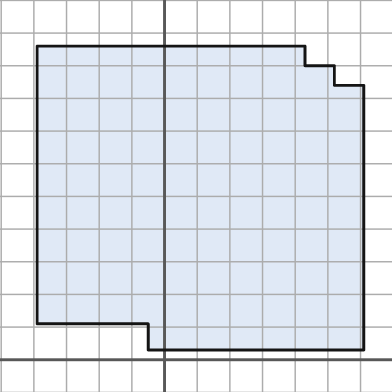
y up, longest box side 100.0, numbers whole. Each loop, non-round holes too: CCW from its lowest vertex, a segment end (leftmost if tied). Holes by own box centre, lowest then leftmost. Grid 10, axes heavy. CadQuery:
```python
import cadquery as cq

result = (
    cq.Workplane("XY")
    .moveTo(-5.0, 3.0)
    .lineTo(61.0, 3.0)
    .lineTo(61.0, 84.0)
    .lineTo(52.0, 84.0)
    .lineTo(52.0, 90.0)
    .lineTo(43.0, 90.0)
    .lineTo(43.0, 96.0)
    .lineTo(-39.0, 96.0)
    .lineTo(-39.0, 11.0)
    .lineTo(-5.0, 11.0)
    .close()
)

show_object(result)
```